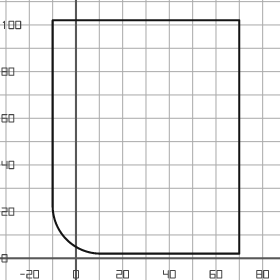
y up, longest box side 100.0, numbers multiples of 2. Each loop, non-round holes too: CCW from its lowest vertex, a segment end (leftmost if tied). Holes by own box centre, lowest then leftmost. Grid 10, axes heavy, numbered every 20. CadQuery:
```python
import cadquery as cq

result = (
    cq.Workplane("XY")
    .moveTo(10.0, 2.0)
    .lineTo(70.0, 2.0)
    .lineTo(70.0, 102.0)
    .lineTo(-10.0, 102.0)
    .lineTo(-10.0, 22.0)
    .threePointArc((-4.0, 8.0), (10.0, 2.0))
    .close()
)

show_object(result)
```